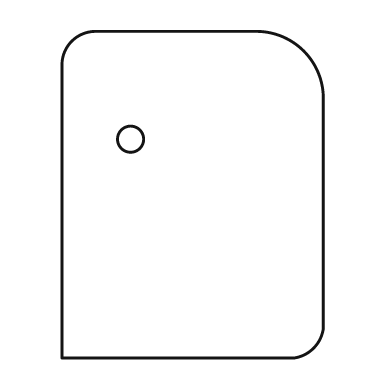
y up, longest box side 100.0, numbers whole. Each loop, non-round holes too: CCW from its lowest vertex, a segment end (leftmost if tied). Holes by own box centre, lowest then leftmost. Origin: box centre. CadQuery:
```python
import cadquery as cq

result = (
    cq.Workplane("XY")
    .moveTo(-40.0, -50.0)
    .lineTo(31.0, -50.0)
    .threePointArc((37.0, -47.0), (40.0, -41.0))
    .lineTo(40.0, 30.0)
    .threePointArc((34.0, 44.0), (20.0, 50.0))
    .lineTo(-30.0, 50.0)
    .threePointArc((-37.0, 47.0), (-40.0, 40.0))
    .close()
    .moveTo(-19.0, 17.0)
    .circle(4.0)
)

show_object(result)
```